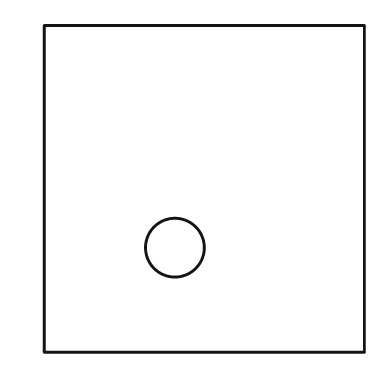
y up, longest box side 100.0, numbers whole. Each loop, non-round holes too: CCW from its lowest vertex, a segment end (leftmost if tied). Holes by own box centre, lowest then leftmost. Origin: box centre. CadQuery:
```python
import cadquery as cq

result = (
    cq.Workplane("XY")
    .moveTo(-49.0, -50.0)
    .lineTo(49.0, -50.0)
    .lineTo(49.0, 50.0)
    .lineTo(-49.0, 50.0)
    .close()
    .moveTo(-9.0, -18.0)
    .circle(9.0)
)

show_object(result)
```